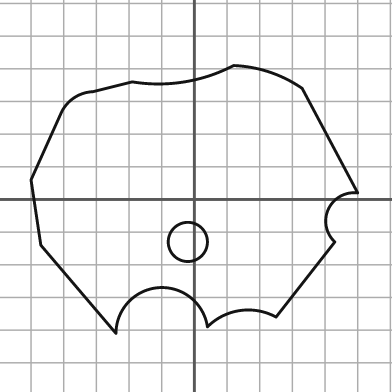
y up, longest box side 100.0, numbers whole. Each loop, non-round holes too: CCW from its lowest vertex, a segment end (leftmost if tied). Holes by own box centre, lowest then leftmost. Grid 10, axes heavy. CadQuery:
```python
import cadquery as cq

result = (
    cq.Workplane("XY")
    .moveTo(-24.0, -41.0)
    .threePointArc((-11.0, -27.0), (4.0, -39.0))
    .threePointArc((14.0, -34.0), (25.0, -36.0))
    .lineTo(43.0, -13.0)
    .threePointArc((41.0, -3.0), (50.0, 2.0))
    .lineTo(33.0, 34.0)
    .threePointArc((23.0, 39.0), (12.0, 41.0))
    .threePointArc((-3.0, 36.0), (-19.0, 36.0))
    .lineTo(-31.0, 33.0)
    .threePointArc((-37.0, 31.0), (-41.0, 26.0))
    .lineTo(-50.0, 6.0)
    .lineTo(-47.0, -14.0)
    .close()
    .moveTo(-2.0, -13.0)
    .circle(6.0)
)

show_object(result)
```